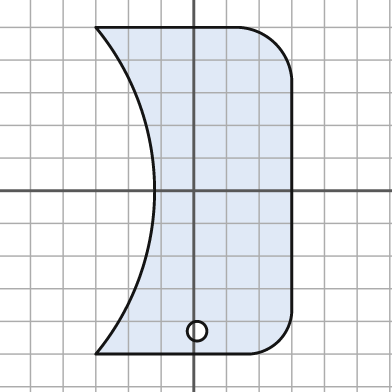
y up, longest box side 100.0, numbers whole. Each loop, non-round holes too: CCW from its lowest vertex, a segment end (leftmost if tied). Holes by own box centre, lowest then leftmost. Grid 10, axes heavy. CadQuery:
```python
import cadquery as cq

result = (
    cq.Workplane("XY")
    .moveTo(-30.0, -50.0)
    .lineTo(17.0, -50.0)
    .threePointArc((26.0, -46.0), (30.0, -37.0))
    .lineTo(30.0, 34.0)
    .threePointArc((25.0, 45.0), (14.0, 50.0))
    .lineTo(-30.0, 50.0)
    .threePointArc((-12.0, 0.0), (-30.0, -50.0))
    .close()
    .moveTo(1.0, -43.0)
    .circle(3.0)
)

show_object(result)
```